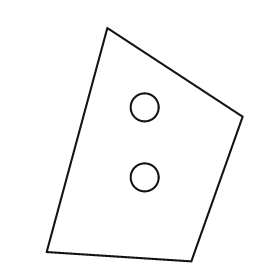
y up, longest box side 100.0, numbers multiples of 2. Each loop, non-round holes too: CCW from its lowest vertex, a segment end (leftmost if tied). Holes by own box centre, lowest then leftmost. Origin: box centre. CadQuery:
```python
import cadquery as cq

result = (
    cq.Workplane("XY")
    .moveTo(20.0, -50.0)
    .lineTo(42.0, 12.0)
    .lineTo(-16.0, 50.0)
    .lineTo(-42.0, -46.0)
    .close()
    .moveTo(0.0, -14.0)
    .circle(6.0)
    .moveTo(0.0, 16.0)
    .circle(6.0)
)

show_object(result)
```